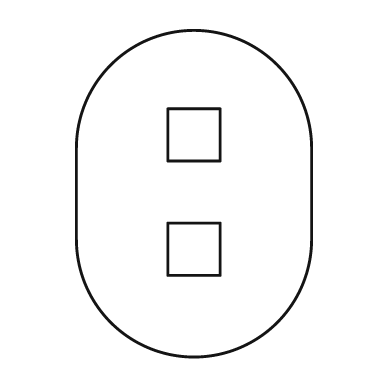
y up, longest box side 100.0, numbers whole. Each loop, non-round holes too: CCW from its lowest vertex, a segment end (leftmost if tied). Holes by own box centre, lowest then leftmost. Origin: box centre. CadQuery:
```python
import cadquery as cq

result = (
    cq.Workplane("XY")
    .moveTo(-36.0, -14.0)
    .threePointArc((0.0, -50.0), (36.0, -14.0))
    .lineTo(36.0, 14.0)
    .threePointArc((0.0, 50.0), (-36.0, 14.0))
    .close()
    .moveTo(-8.0, -25.0)
    .lineTo(8.0, -25.0)
    .lineTo(8.0, -9.0)
    .lineTo(-8.0, -9.0)
    .close()
    .moveTo(-8.0, 10.0)
    .lineTo(8.0, 10.0)
    .lineTo(8.0, 26.0)
    .lineTo(-8.0, 26.0)
    .close()
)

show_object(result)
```